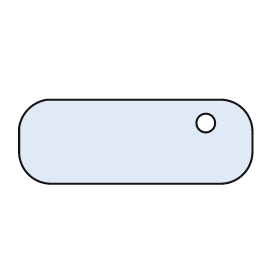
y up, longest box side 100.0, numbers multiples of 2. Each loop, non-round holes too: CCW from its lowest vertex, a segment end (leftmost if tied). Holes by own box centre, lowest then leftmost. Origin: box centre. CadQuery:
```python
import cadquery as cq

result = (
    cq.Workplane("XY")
    .moveTo(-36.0, -18.0)
    .lineTo(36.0, -18.0)
    .threePointArc((46.0, -14.0), (50.0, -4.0))
    .lineTo(50.0, 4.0)
    .threePointArc((46.0, 14.0), (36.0, 18.0))
    .lineTo(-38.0, 18.0)
    .threePointArc((-46.0, 14.0), (-50.0, 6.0))
    .lineTo(-50.0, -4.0)
    .threePointArc((-46.0, -14.0), (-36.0, -18.0))
    .close()
    .moveTo(30.0, 8.0)
    .circle(4.0)
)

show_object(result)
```